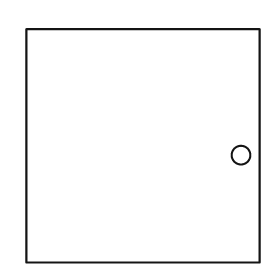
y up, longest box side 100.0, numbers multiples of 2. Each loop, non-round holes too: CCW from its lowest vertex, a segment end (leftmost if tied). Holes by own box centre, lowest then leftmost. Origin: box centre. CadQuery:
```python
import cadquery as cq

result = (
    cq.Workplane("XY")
    .moveTo(-50.0, -50.0)
    .lineTo(50.0, -50.0)
    .lineTo(50.0, 50.0)
    .lineTo(-50.0, 50.0)
    .close()
    .moveTo(42.0, -4.0)
    .circle(4.0)
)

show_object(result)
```